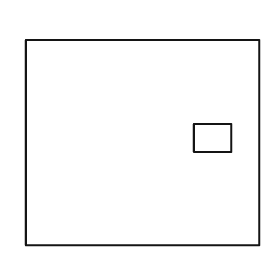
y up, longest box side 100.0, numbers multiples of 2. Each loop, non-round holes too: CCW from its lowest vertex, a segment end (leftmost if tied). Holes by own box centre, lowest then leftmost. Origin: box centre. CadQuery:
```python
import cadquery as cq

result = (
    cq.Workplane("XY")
    .moveTo(-50.0, -44.0)
    .lineTo(50.0, -44.0)
    .lineTo(50.0, 44.0)
    .lineTo(-50.0, 44.0)
    .close()
    .moveTo(22.0, -4.0)
    .lineTo(38.0, -4.0)
    .lineTo(38.0, 8.0)
    .lineTo(22.0, 8.0)
    .close()
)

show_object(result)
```